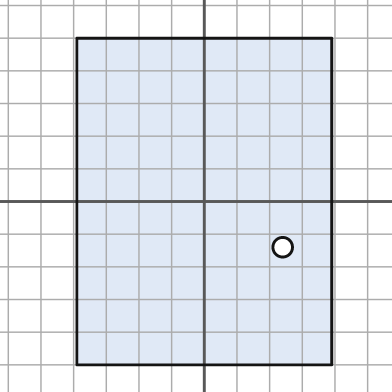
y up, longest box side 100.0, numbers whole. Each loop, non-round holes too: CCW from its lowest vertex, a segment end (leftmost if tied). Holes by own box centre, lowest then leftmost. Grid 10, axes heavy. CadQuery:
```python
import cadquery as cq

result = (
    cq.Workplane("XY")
    .moveTo(-39.0, -50.0)
    .lineTo(39.0, -50.0)
    .lineTo(39.0, 50.0)
    .lineTo(-39.0, 50.0)
    .close()
    .moveTo(24.0, -14.0)
    .circle(3.0)
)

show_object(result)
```